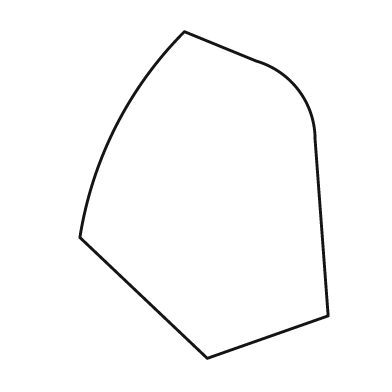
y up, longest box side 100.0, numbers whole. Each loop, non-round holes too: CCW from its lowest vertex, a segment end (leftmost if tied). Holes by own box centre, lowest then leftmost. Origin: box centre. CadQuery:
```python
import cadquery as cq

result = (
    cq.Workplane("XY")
    .moveTo(1.0, -50.0)
    .lineTo(38.0, -37.0)
    .lineTo(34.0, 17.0)
    .threePointArc((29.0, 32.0), (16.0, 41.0))
    .lineTo(-6.0, 50.0)
    .threePointArc((-27.0, 21.0), (-38.0, -13.0))
    .close()
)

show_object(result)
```